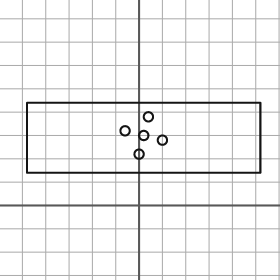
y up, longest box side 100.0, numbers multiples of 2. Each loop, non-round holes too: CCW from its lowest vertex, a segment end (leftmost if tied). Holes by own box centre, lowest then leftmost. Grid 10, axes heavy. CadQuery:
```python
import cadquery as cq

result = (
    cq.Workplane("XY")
    .moveTo(-48.0, 14.0)
    .lineTo(52.0, 14.0)
    .lineTo(52.0, 44.0)
    .lineTo(-48.0, 44.0)
    .close()
    .moveTo(0.0, 22.0)
    .circle(2.0)
    .moveTo(10.0, 28.0)
    .circle(2.0)
    .moveTo(2.0, 30.0)
    .circle(2.0)
    .moveTo(-6.0, 32.0)
    .circle(2.0)
    .moveTo(4.0, 38.0)
    .circle(2.0)
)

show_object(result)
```